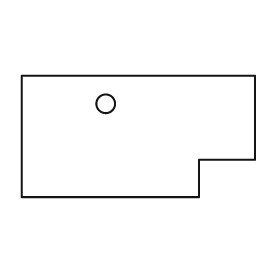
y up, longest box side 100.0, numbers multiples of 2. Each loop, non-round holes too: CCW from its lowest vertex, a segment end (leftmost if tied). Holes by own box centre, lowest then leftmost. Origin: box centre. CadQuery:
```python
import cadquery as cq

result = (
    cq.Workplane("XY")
    .moveTo(-50.0, -26.0)
    .lineTo(26.0, -26.0)
    .lineTo(26.0, -10.0)
    .lineTo(50.0, -10.0)
    .lineTo(50.0, 26.0)
    .lineTo(-50.0, 26.0)
    .close()
    .moveTo(-14.0, 14.0)
    .circle(4.0)
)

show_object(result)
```